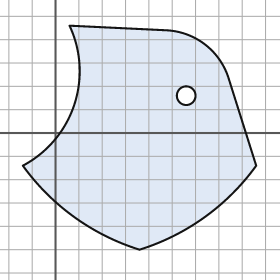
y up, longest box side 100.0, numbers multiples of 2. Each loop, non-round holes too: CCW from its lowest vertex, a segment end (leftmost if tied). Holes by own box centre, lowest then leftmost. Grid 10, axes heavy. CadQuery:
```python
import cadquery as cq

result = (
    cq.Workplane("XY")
    .moveTo(36.0, -50.0)
    .threePointArc((64.0, -36.0), (86.0, -14.0))
    .lineTo(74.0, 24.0)
    .threePointArc((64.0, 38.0), (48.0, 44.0))
    .lineTo(6.0, 46.0)
    .threePointArc((8.0, 12.0), (-14.0, -14.0))
    .threePointArc((8.0, -36.0), (36.0, -50.0))
    .close()
    .moveTo(56.0, 16.0)
    .circle(4.0)
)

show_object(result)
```